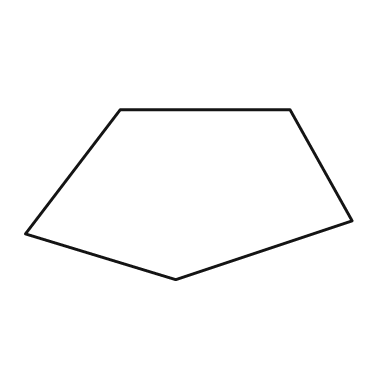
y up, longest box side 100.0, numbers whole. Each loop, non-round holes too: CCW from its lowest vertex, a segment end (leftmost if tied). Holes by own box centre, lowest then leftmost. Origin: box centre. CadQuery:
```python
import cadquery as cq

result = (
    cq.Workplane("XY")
    .moveTo(-4.0, -26.0)
    .lineTo(50.0, -8.0)
    .lineTo(31.0, 26.0)
    .lineTo(-21.0, 26.0)
    .lineTo(-50.0, -12.0)
    .close()
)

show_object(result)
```